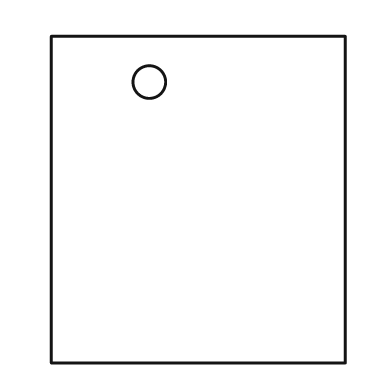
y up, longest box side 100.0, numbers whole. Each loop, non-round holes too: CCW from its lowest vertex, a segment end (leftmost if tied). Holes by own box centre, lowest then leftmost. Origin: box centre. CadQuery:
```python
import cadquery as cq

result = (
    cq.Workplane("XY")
    .moveTo(-45.0, -50.0)
    .lineTo(45.0, -50.0)
    .lineTo(45.0, 50.0)
    .lineTo(-45.0, 50.0)
    .close()
    .moveTo(-15.0, 36.0)
    .circle(5.0)
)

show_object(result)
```